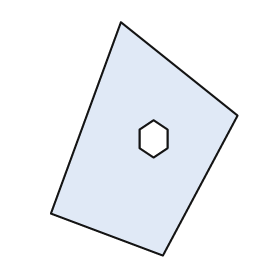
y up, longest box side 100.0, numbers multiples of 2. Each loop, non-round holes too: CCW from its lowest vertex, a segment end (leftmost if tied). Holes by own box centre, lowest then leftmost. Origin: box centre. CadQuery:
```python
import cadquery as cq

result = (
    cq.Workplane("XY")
    .moveTo(8.0, -50.0)
    .lineTo(40.0, 10.0)
    .lineTo(-10.0, 50.0)
    .lineTo(-40.0, -32.0)
    .close()
    .moveTo(4.0, -8.0)
    .lineTo(10.0, -4.0)
    .lineTo(10.0, 4.0)
    .lineTo(4.0, 8.0)
    .lineTo(-2.0, 4.0)
    .lineTo(-2.0, -4.0)
    .close()
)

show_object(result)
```